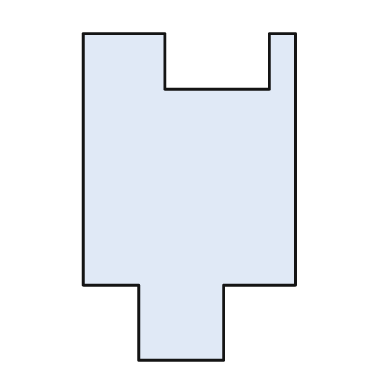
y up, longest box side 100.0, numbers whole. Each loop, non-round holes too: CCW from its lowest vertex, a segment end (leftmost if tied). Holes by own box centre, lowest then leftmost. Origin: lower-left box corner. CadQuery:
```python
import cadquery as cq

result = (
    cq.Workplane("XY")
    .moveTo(17.0, 0.0)
    .lineTo(43.0, 0.0)
    .lineTo(43.0, 23.0)
    .lineTo(65.0, 23.0)
    .lineTo(65.0, 100.0)
    .lineTo(57.0, 100.0)
    .lineTo(57.0, 83.0)
    .lineTo(25.0, 83.0)
    .lineTo(25.0, 100.0)
    .lineTo(0.0, 100.0)
    .lineTo(0.0, 23.0)
    .lineTo(17.0, 23.0)
    .close()
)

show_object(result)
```